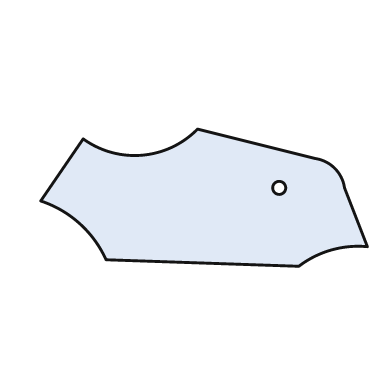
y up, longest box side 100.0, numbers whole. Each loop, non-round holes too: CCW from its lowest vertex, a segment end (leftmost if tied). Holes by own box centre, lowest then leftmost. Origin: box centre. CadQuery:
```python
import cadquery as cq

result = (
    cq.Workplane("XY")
    .moveTo(29.0, -21.0)
    .threePointArc((39.0, -16.0), (50.0, -15.0))
    .lineTo(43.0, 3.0)
    .threePointArc((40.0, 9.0), (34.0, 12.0))
    .lineTo(-2.0, 21.0)
    .threePointArc((-19.0, 13.0), (-37.0, 18.0))
    .lineTo(-50.0, -1.0)
    .threePointArc((-38.0, -8.0), (-30.0, -19.0))
    .close()
    .moveTo(23.0, 3.0)
    .circle(2.0)
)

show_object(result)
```